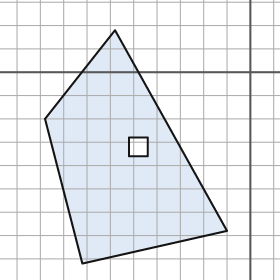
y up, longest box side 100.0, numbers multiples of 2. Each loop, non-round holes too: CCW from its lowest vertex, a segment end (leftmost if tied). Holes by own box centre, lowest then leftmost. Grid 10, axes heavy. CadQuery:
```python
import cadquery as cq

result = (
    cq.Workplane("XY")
    .moveTo(-72.0, -82.0)
    .lineTo(-10.0, -68.0)
    .lineTo(-58.0, 18.0)
    .lineTo(-88.0, -20.0)
    .close()
    .moveTo(-52.0, -36.0)
    .lineTo(-44.0, -36.0)
    .lineTo(-44.0, -28.0)
    .lineTo(-52.0, -28.0)
    .close()
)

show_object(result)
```